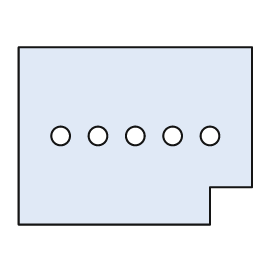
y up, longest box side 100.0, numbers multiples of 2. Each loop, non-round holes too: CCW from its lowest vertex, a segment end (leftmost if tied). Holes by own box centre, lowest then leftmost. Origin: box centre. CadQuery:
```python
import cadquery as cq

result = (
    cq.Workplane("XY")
    .moveTo(-50.0, -38.0)
    .lineTo(32.0, -38.0)
    .lineTo(32.0, -22.0)
    .lineTo(50.0, -22.0)
    .lineTo(50.0, 38.0)
    .lineTo(-50.0, 38.0)
    .close()
    .moveTo(-32.0, 0.0)
    .circle(4.0)
    .moveTo(-16.0, 0.0)
    .circle(4.0)
    .moveTo(0.0, 0.0)
    .circle(4.0)
    .moveTo(16.0, 0.0)
    .circle(4.0)
    .moveTo(32.0, 0.0)
    .circle(4.0)
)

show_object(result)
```